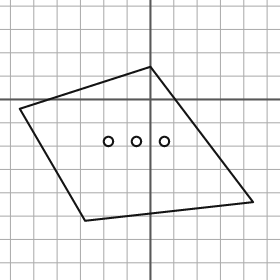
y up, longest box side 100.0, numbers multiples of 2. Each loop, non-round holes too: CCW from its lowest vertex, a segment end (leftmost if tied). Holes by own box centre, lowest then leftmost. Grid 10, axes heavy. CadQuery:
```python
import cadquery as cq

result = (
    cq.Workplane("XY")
    .moveTo(-28.0, -52.0)
    .lineTo(44.0, -44.0)
    .lineTo(0.0, 14.0)
    .lineTo(-56.0, -4.0)
    .close()
    .moveTo(-18.0, -18.0)
    .circle(2.0)
    .moveTo(-6.0, -18.0)
    .circle(2.0)
    .moveTo(6.0, -18.0)
    .circle(2.0)
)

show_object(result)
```